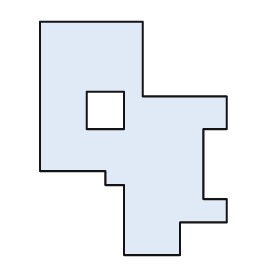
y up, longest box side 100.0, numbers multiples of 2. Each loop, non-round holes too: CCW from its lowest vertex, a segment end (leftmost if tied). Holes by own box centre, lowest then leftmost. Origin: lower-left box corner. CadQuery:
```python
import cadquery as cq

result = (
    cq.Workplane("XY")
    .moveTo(36.0, 0.0)
    .lineTo(60.0, 0.0)
    .lineTo(60.0, 14.0)
    .lineTo(80.0, 14.0)
    .lineTo(80.0, 24.0)
    .lineTo(70.0, 24.0)
    .lineTo(70.0, 54.0)
    .lineTo(80.0, 54.0)
    .lineTo(80.0, 68.0)
    .lineTo(44.0, 68.0)
    .lineTo(44.0, 100.0)
    .lineTo(0.0, 100.0)
    .lineTo(0.0, 36.0)
    .lineTo(28.0, 36.0)
    .lineTo(28.0, 30.0)
    .lineTo(36.0, 30.0)
    .close()
    .moveTo(20.0, 54.0)
    .lineTo(36.0, 54.0)
    .lineTo(36.0, 70.0)
    .lineTo(20.0, 70.0)
    .close()
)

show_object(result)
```